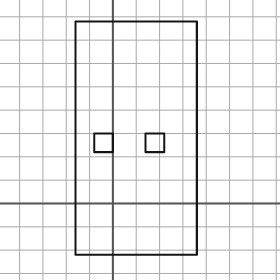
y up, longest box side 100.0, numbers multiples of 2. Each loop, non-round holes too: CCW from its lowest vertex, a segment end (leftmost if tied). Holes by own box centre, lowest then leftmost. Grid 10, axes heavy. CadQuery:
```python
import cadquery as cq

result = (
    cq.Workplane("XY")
    .moveTo(-16.0, -22.0)
    .lineTo(36.0, -22.0)
    .lineTo(36.0, 78.0)
    .lineTo(-16.0, 78.0)
    .close()
    .moveTo(-8.0, 22.0)
    .lineTo(0.0, 22.0)
    .lineTo(0.0, 30.0)
    .lineTo(-8.0, 30.0)
    .close()
    .moveTo(14.0, 22.0)
    .lineTo(22.0, 22.0)
    .lineTo(22.0, 30.0)
    .lineTo(14.0, 30.0)
    .close()
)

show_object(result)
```